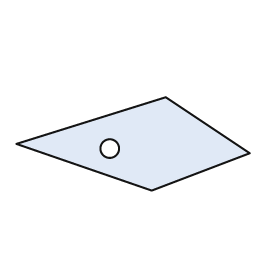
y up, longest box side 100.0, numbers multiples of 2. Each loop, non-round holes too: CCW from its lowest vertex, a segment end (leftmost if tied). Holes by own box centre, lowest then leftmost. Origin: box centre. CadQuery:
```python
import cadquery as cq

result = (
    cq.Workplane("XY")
    .moveTo(8.0, -20.0)
    .lineTo(50.0, -4.0)
    .lineTo(14.0, 20.0)
    .lineTo(-50.0, 0.0)
    .close()
    .moveTo(-10.0, -2.0)
    .circle(4.0)
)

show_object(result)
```